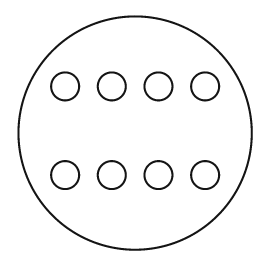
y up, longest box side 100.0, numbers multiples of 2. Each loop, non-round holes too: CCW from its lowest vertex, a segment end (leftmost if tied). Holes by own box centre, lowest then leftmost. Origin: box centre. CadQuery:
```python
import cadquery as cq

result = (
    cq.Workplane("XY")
    .moveTo(0.0, 0.0)
    .circle(50.0)
    .moveTo(-30.0, -18.0)
    .circle(6.0)
    .moveTo(-10.0, -18.0)
    .circle(6.0)
    .moveTo(10.0, -18.0)
    .circle(6.0)
    .moveTo(30.0, -18.0)
    .circle(6.0)
    .moveTo(-30.0, 20.0)
    .circle(6.0)
    .moveTo(-10.0, 20.0)
    .circle(6.0)
    .moveTo(10.0, 20.0)
    .circle(6.0)
    .moveTo(30.0, 20.0)
    .circle(6.0)
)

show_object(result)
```